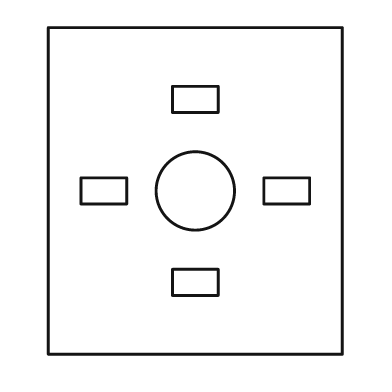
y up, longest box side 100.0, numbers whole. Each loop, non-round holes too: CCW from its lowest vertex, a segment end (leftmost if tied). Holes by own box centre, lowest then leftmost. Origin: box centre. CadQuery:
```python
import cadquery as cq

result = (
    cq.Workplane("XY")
    .moveTo(-45.0, -50.0)
    .lineTo(45.0, -50.0)
    .lineTo(45.0, 50.0)
    .lineTo(-45.0, 50.0)
    .close()
    .moveTo(-7.0, -32.0)
    .lineTo(7.0, -32.0)
    .lineTo(7.0, -24.0)
    .lineTo(-7.0, -24.0)
    .close()
    .moveTo(-35.0, -4.0)
    .lineTo(-21.0, -4.0)
    .lineTo(-21.0, 4.0)
    .lineTo(-35.0, 4.0)
    .close()
    .moveTo(0.0, 0.0)
    .circle(12.0)
    .moveTo(21.0, -4.0)
    .lineTo(35.0, -4.0)
    .lineTo(35.0, 4.0)
    .lineTo(21.0, 4.0)
    .close()
    .moveTo(-7.0, 24.0)
    .lineTo(7.0, 24.0)
    .lineTo(7.0, 32.0)
    .lineTo(-7.0, 32.0)
    .close()
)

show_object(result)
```